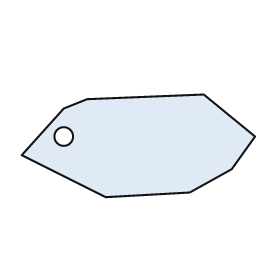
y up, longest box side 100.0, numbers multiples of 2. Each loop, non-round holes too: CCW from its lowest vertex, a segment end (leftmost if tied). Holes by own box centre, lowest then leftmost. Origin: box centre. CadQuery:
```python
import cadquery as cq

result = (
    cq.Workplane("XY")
    .moveTo(-14.0, -22.0)
    .lineTo(22.0, -20.0)
    .lineTo(40.0, -10.0)
    .lineTo(50.0, 4.0)
    .lineTo(28.0, 22.0)
    .lineTo(-22.0, 20.0)
    .lineTo(-32.0, 16.0)
    .lineTo(-50.0, -4.0)
    .close()
    .moveTo(-32.0, 4.0)
    .circle(4.0)
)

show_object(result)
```